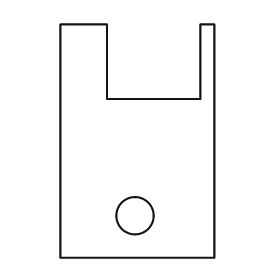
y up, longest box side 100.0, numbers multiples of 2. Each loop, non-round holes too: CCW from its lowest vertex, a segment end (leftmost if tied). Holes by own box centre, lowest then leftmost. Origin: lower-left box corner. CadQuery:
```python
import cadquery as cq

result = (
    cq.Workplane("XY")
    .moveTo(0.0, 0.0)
    .lineTo(66.0, 0.0)
    .lineTo(66.0, 100.0)
    .lineTo(60.0, 100.0)
    .lineTo(60.0, 68.0)
    .lineTo(20.0, 68.0)
    .lineTo(20.0, 100.0)
    .lineTo(0.0, 100.0)
    .close()
    .moveTo(32.0, 18.0)
    .circle(8.0)
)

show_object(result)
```